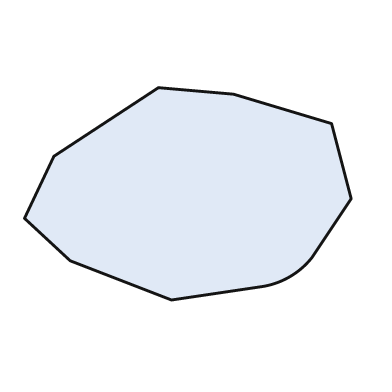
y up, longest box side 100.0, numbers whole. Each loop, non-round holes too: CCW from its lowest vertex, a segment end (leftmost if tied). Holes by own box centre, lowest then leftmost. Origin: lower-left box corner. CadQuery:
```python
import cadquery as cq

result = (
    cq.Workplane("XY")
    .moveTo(45.0, 0.0)
    .lineTo(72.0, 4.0)
    .threePointArc((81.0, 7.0), (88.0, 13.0))
    .lineTo(100.0, 31.0)
    .lineTo(94.0, 54.0)
    .lineTo(64.0, 63.0)
    .lineTo(41.0, 65.0)
    .lineTo(9.0, 44.0)
    .lineTo(0.0, 25.0)
    .lineTo(14.0, 12.0)
    .close()
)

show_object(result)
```